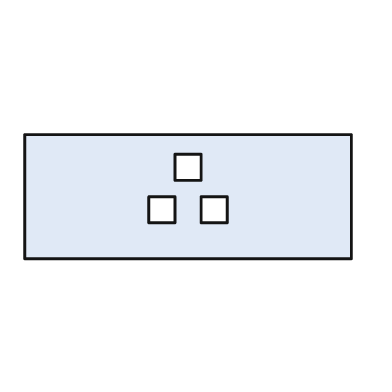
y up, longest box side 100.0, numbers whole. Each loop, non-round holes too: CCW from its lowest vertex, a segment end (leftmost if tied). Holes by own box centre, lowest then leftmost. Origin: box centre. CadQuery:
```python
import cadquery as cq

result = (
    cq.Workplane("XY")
    .moveTo(-50.0, -19.0)
    .lineTo(50.0, -19.0)
    .lineTo(50.0, 19.0)
    .lineTo(-50.0, 19.0)
    .close()
    .moveTo(-12.0, -8.0)
    .lineTo(-4.0, -8.0)
    .lineTo(-4.0, 0.0)
    .lineTo(-12.0, 0.0)
    .close()
    .moveTo(4.0, -8.0)
    .lineTo(12.0, -8.0)
    .lineTo(12.0, 0.0)
    .lineTo(4.0, 0.0)
    .close()
    .moveTo(-4.0, 5.0)
    .lineTo(4.0, 5.0)
    .lineTo(4.0, 13.0)
    .lineTo(-4.0, 13.0)
    .close()
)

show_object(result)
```